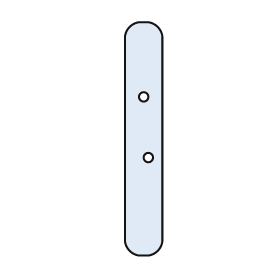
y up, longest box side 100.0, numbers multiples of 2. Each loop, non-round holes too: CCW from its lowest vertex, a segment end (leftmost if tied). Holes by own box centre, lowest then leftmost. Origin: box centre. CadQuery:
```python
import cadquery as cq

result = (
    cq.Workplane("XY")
    .moveTo(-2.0, -50.0)
    .lineTo(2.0, -50.0)
    .threePointArc((6.0, -48.0), (8.0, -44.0))
    .lineTo(8.0, 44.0)
    .threePointArc((6.0, 48.0), (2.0, 50.0))
    .lineTo(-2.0, 50.0)
    .threePointArc((-6.0, 48.0), (-8.0, 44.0))
    .lineTo(-8.0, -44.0)
    .threePointArc((-6.0, -48.0), (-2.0, -50.0))
    .close()
    .moveTo(2.0, -8.0)
    .circle(2.0)
    .moveTo(0.0, 18.0)
    .circle(2.0)
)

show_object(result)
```